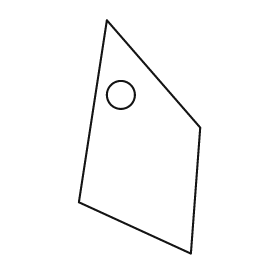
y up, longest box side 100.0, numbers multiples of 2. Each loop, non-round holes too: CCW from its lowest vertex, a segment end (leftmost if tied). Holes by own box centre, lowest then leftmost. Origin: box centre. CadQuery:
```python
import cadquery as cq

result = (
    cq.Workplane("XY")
    .moveTo(22.0, -50.0)
    .lineTo(26.0, 4.0)
    .lineTo(-14.0, 50.0)
    .lineTo(-26.0, -28.0)
    .close()
    .moveTo(-8.0, 18.0)
    .circle(6.0)
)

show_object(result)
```